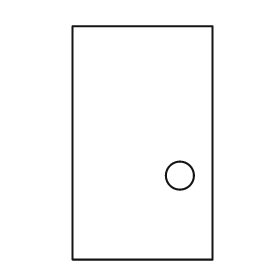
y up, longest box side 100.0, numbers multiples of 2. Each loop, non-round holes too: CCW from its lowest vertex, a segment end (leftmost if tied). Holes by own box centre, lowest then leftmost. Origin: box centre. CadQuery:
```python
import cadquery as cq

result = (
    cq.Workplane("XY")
    .moveTo(-30.0, -50.0)
    .lineTo(30.0, -50.0)
    .lineTo(30.0, 50.0)
    .lineTo(-30.0, 50.0)
    .close()
    .moveTo(16.0, -14.0)
    .circle(6.0)
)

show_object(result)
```